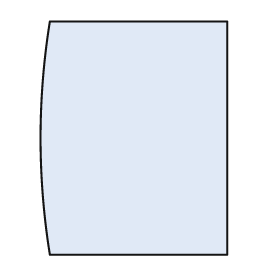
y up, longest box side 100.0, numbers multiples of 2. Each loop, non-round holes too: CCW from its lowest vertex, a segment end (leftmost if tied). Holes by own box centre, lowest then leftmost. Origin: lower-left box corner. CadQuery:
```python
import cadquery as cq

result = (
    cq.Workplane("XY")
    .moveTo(4.0, 0.0)
    .lineTo(80.0, 0.0)
    .lineTo(80.0, 100.0)
    .lineTo(4.0, 100.0)
    .threePointArc((0.0, 50.0), (4.0, 0.0))
    .close()
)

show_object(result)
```